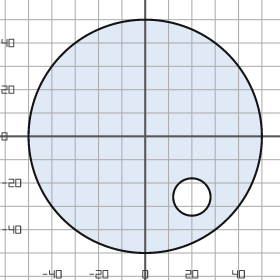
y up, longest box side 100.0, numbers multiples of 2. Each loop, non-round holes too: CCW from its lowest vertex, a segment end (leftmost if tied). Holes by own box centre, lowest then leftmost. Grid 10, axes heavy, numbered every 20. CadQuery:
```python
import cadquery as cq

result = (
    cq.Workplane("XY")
    .moveTo(0.0, 0.0)
    .circle(50.0)
    .moveTo(20.0, -26.0)
    .circle(8.0)
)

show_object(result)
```